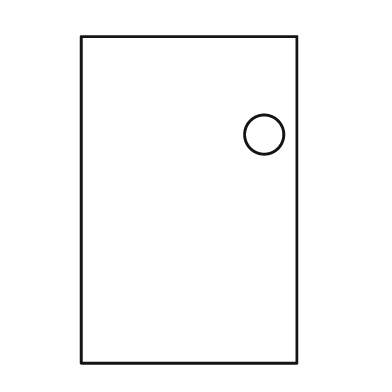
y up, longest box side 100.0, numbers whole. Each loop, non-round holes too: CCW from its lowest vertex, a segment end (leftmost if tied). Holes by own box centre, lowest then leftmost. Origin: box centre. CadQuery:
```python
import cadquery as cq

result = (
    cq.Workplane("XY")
    .moveTo(-33.0, -50.0)
    .lineTo(33.0, -50.0)
    .lineTo(33.0, 50.0)
    .lineTo(-33.0, 50.0)
    .close()
    .moveTo(23.0, 20.0)
    .circle(6.0)
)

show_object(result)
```